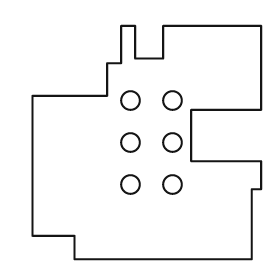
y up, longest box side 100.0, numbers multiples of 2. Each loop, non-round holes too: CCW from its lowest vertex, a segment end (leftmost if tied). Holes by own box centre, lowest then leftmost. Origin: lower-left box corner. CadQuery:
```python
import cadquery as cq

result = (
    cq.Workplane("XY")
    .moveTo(18.0, 0.0)
    .lineTo(94.0, 0.0)
    .lineTo(94.0, 30.0)
    .lineTo(98.0, 30.0)
    .lineTo(98.0, 42.0)
    .lineTo(68.0, 42.0)
    .lineTo(68.0, 64.0)
    .lineTo(98.0, 64.0)
    .lineTo(98.0, 100.0)
    .lineTo(56.0, 100.0)
    .lineTo(56.0, 86.0)
    .lineTo(44.0, 86.0)
    .lineTo(44.0, 100.0)
    .lineTo(38.0, 100.0)
    .lineTo(38.0, 84.0)
    .lineTo(32.0, 84.0)
    .lineTo(32.0, 70.0)
    .lineTo(0.0, 70.0)
    .lineTo(0.0, 10.0)
    .lineTo(18.0, 10.0)
    .close()
    .moveTo(42.0, 32.0)
    .circle(4.0)
    .moveTo(60.0, 32.0)
    .circle(4.0)
    .moveTo(42.0, 50.0)
    .circle(4.0)
    .moveTo(60.0, 50.0)
    .circle(4.0)
    .moveTo(42.0, 68.0)
    .circle(4.0)
    .moveTo(60.0, 68.0)
    .circle(4.0)
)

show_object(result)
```